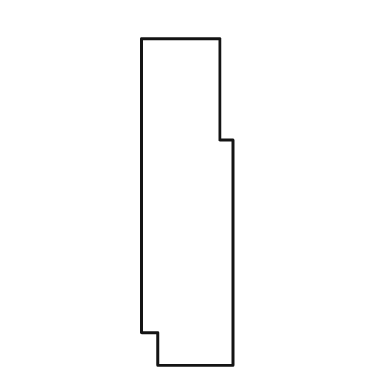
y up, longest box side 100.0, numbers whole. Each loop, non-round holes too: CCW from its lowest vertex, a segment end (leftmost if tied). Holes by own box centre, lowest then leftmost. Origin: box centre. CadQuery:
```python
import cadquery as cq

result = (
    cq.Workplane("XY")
    .moveTo(-9.0, -50.0)
    .lineTo(14.0, -50.0)
    .lineTo(14.0, 19.0)
    .lineTo(10.0, 19.0)
    .lineTo(10.0, 50.0)
    .lineTo(-14.0, 50.0)
    .lineTo(-14.0, -40.0)
    .lineTo(-9.0, -40.0)
    .close()
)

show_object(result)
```